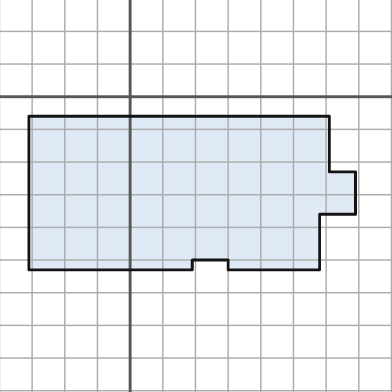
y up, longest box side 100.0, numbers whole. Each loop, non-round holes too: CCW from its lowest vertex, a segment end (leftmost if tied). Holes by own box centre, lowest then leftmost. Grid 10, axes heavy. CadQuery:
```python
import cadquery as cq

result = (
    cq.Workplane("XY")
    .moveTo(-31.0, -53.0)
    .lineTo(19.0, -53.0)
    .lineTo(19.0, -50.0)
    .lineTo(30.0, -50.0)
    .lineTo(30.0, -53.0)
    .lineTo(58.0, -53.0)
    .lineTo(58.0, -36.0)
    .lineTo(69.0, -36.0)
    .lineTo(69.0, -23.0)
    .lineTo(61.0, -23.0)
    .lineTo(61.0, -6.0)
    .lineTo(-31.0, -6.0)
    .close()
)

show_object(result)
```